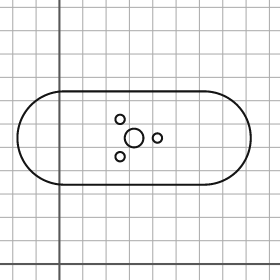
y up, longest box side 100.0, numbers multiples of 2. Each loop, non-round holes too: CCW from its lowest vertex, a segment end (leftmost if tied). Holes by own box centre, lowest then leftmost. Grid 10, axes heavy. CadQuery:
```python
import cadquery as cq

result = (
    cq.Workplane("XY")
    .moveTo(2.0, 34.0)
    .lineTo(62.0, 34.0)
    .threePointArc((82.0, 54.0), (62.0, 74.0))
    .lineTo(2.0, 74.0)
    .threePointArc((-18.0, 54.0), (2.0, 34.0))
    .close()
    .moveTo(26.0, 46.0)
    .circle(2.0)
    .moveTo(32.0, 54.0)
    .circle(4.0)
    .moveTo(42.0, 54.0)
    .circle(2.0)
    .moveTo(26.0, 62.0)
    .circle(2.0)
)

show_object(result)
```